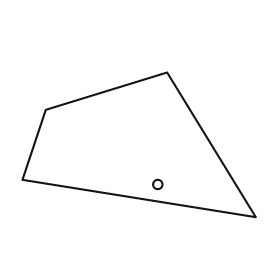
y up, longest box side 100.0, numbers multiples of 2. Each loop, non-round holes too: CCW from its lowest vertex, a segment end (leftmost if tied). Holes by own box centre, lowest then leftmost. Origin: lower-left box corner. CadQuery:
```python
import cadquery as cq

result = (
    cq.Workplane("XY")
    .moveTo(100.0, 0.0)
    .lineTo(62.0, 62.0)
    .lineTo(10.0, 46.0)
    .lineTo(0.0, 16.0)
    .close()
    .moveTo(58.0, 14.0)
    .circle(2.0)
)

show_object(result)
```